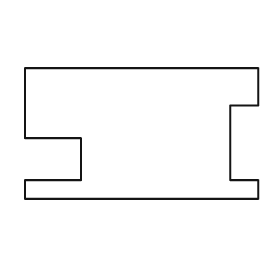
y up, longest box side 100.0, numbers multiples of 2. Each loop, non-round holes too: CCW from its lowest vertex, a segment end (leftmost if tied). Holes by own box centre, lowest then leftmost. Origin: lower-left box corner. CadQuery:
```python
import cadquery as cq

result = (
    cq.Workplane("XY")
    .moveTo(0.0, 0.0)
    .lineTo(100.0, 0.0)
    .lineTo(100.0, 8.0)
    .lineTo(88.0, 8.0)
    .lineTo(88.0, 40.0)
    .lineTo(100.0, 40.0)
    .lineTo(100.0, 56.0)
    .lineTo(0.0, 56.0)
    .lineTo(0.0, 26.0)
    .lineTo(24.0, 26.0)
    .lineTo(24.0, 8.0)
    .lineTo(0.0, 8.0)
    .close()
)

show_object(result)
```